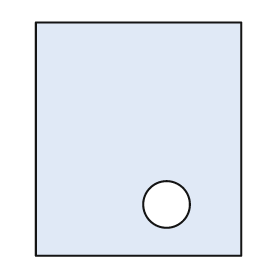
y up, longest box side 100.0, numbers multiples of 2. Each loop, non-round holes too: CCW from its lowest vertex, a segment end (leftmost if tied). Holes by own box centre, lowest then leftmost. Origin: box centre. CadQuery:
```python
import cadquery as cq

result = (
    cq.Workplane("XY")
    .moveTo(-44.0, -50.0)
    .lineTo(44.0, -50.0)
    .lineTo(44.0, 50.0)
    .lineTo(-44.0, 50.0)
    .close()
    .moveTo(12.0, -28.0)
    .circle(10.0)
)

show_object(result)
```